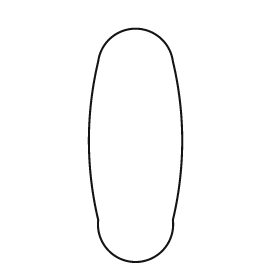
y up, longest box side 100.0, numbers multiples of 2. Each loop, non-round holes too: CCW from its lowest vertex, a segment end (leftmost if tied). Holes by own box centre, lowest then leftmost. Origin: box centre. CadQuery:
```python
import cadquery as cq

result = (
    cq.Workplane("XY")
    .moveTo(-16.0, -32.0)
    .threePointArc((0.0, -50.0), (16.0, -32.0))
    .threePointArc((20.0, 2.0), (16.0, 36.0))
    .threePointArc((0.0, 50.0), (-16.0, 36.0))
    .threePointArc((-20.0, 2.0), (-16.0, -32.0))
    .close()
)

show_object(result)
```